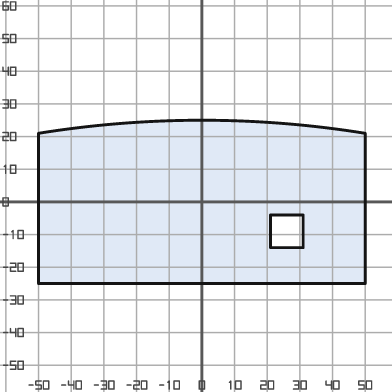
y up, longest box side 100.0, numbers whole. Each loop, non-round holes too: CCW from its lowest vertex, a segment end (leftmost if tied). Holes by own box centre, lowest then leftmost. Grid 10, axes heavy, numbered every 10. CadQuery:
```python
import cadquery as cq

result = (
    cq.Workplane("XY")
    .moveTo(-50.0, -25.0)
    .lineTo(50.0, -25.0)
    .lineTo(50.0, 21.0)
    .threePointArc((0.0, 25.0), (-50.0, 21.0))
    .close()
    .moveTo(21.0, -14.0)
    .lineTo(31.0, -14.0)
    .lineTo(31.0, -4.0)
    .lineTo(21.0, -4.0)
    .close()
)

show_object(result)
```